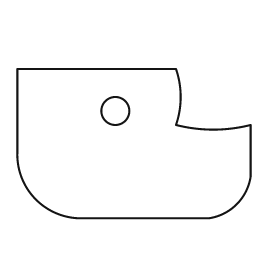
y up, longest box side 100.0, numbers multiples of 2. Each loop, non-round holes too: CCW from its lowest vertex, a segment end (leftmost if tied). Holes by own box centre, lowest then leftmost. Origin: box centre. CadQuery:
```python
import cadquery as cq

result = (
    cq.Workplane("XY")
    .moveTo(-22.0, -32.0)
    .lineTo(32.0, -32.0)
    .threePointArc((44.0, -26.0), (50.0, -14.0))
    .lineTo(50.0, 8.0)
    .threePointArc((34.0, 6.0), (18.0, 8.0))
    .threePointArc((20.0, 20.0), (18.0, 32.0))
    .lineTo(-50.0, 32.0)
    .lineTo(-50.0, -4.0)
    .threePointArc((-42.0, -24.0), (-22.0, -32.0))
    .close()
    .moveTo(-8.0, 14.0)
    .circle(6.0)
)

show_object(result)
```